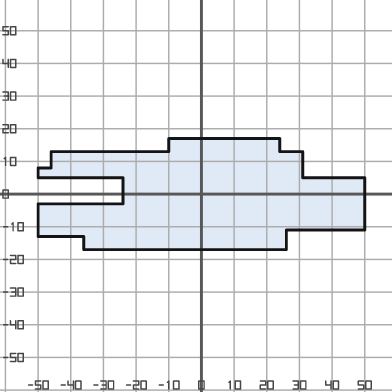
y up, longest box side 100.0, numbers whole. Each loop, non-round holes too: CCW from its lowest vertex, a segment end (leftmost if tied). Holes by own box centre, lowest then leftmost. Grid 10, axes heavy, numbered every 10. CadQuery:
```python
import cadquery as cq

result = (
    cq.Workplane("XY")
    .moveTo(-36.0, -17.0)
    .lineTo(26.0, -17.0)
    .lineTo(26.0, -11.0)
    .lineTo(50.0, -11.0)
    .lineTo(50.0, 5.0)
    .lineTo(31.0, 5.0)
    .lineTo(31.0, 13.0)
    .lineTo(24.0, 13.0)
    .lineTo(24.0, 17.0)
    .lineTo(-10.0, 17.0)
    .lineTo(-10.0, 13.0)
    .lineTo(-46.0, 13.0)
    .lineTo(-46.0, 8.0)
    .lineTo(-50.0, 8.0)
    .lineTo(-50.0, 5.0)
    .lineTo(-24.0, 5.0)
    .lineTo(-24.0, -3.0)
    .lineTo(-50.0, -3.0)
    .lineTo(-50.0, -13.0)
    .lineTo(-36.0, -13.0)
    .close()
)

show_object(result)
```